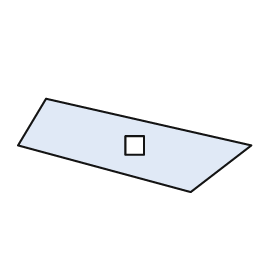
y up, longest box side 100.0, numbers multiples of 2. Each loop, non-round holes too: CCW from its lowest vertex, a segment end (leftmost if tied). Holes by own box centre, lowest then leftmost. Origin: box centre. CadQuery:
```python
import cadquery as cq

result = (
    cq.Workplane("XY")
    .moveTo(24.0, -20.0)
    .lineTo(50.0, 0.0)
    .lineTo(-38.0, 20.0)
    .lineTo(-50.0, 0.0)
    .close()
    .moveTo(-4.0, -4.0)
    .lineTo(4.0, -4.0)
    .lineTo(4.0, 4.0)
    .lineTo(-4.0, 4.0)
    .close()
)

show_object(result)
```